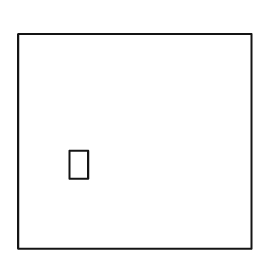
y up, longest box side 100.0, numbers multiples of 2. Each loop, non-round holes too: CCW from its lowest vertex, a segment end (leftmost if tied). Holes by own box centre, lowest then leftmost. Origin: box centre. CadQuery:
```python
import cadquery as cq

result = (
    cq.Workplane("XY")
    .moveTo(-50.0, -46.0)
    .lineTo(50.0, -46.0)
    .lineTo(50.0, 46.0)
    .lineTo(-50.0, 46.0)
    .close()
    .moveTo(-28.0, -16.0)
    .lineTo(-20.0, -16.0)
    .lineTo(-20.0, -4.0)
    .lineTo(-28.0, -4.0)
    .close()
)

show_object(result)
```